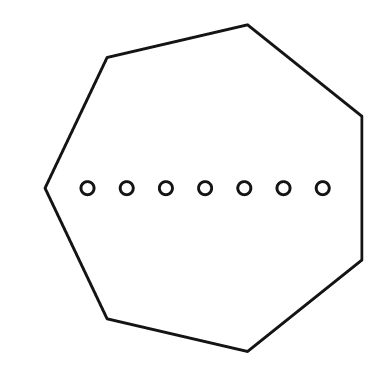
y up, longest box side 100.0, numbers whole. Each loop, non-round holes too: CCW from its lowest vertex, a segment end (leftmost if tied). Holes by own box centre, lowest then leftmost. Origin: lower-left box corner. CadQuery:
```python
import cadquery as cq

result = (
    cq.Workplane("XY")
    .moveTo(62.0, 0.0)
    .lineTo(97.0, 28.0)
    .lineTo(97.0, 72.0)
    .lineTo(62.0, 100.0)
    .lineTo(19.0, 90.0)
    .lineTo(0.0, 50.0)
    .lineTo(19.0, 10.0)
    .close()
    .moveTo(13.0, 50.0)
    .circle(2.0)
    .moveTo(25.0, 50.0)
    .circle(2.0)
    .moveTo(37.0, 50.0)
    .circle(2.0)
    .moveTo(49.0, 50.0)
    .circle(2.0)
    .moveTo(61.0, 50.0)
    .circle(2.0)
    .moveTo(73.0, 50.0)
    .circle(2.0)
    .moveTo(85.0, 50.0)
    .circle(2.0)
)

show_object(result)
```